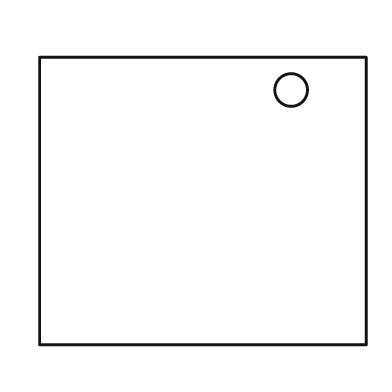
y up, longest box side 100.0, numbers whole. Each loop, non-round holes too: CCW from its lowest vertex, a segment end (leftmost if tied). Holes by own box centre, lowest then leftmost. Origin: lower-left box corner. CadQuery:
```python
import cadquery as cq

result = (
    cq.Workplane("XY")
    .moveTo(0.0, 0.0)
    .lineTo(100.0, 0.0)
    .lineTo(100.0, 88.0)
    .lineTo(0.0, 88.0)
    .close()
    .moveTo(77.0, 78.0)
    .circle(5.0)
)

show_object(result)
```